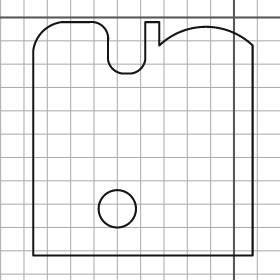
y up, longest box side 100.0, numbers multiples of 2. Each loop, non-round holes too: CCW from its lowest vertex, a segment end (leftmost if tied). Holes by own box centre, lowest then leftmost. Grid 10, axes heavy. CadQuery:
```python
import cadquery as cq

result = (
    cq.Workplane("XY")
    .moveTo(-86.0, -102.0)
    .lineTo(8.0, -102.0)
    .lineTo(8.0, -12.0)
    .threePointArc((-12.0, -4.0), (-32.0, -12.0))
    .lineTo(-32.0, -2.0)
    .lineTo(-38.0, -2.0)
    .lineTo(-38.0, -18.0)
    .threePointArc((-40.0, -22.0), (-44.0, -24.0))
    .lineTo(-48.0, -24.0)
    .threePointArc((-52.0, -22.0), (-54.0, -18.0))
    .lineTo(-54.0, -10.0)
    .threePointArc((-56.0, -4.0), (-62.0, -2.0))
    .lineTo(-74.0, -2.0)
    .threePointArc((-82.0, -6.0), (-86.0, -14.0))
    .close()
    .moveTo(-50.0, -82.0)
    .circle(8.0)
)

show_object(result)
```